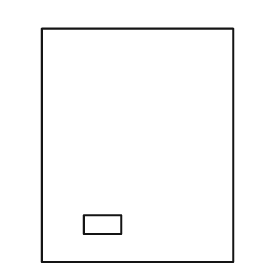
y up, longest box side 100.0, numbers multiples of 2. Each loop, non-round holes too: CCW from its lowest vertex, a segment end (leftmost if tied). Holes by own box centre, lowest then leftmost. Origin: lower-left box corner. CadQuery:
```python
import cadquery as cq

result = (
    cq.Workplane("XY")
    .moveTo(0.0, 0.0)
    .lineTo(82.0, 0.0)
    .lineTo(82.0, 100.0)
    .lineTo(0.0, 100.0)
    .close()
    .moveTo(18.0, 12.0)
    .lineTo(34.0, 12.0)
    .lineTo(34.0, 20.0)
    .lineTo(18.0, 20.0)
    .close()
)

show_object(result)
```